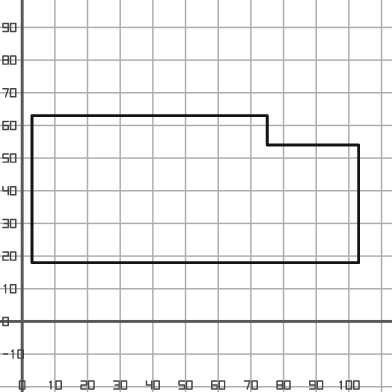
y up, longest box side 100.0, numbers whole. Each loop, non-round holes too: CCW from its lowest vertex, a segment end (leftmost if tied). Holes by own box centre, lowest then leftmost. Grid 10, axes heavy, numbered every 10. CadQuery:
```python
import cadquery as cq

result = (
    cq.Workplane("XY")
    .moveTo(3.0, 18.0)
    .lineTo(103.0, 18.0)
    .lineTo(103.0, 54.0)
    .lineTo(75.0, 54.0)
    .lineTo(75.0, 63.0)
    .lineTo(3.0, 63.0)
    .close()
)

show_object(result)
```